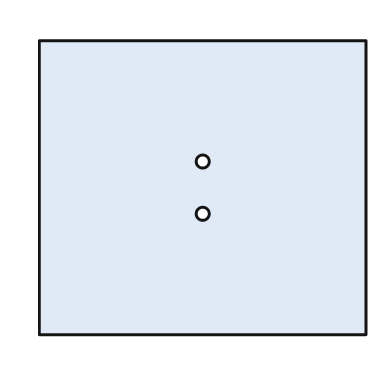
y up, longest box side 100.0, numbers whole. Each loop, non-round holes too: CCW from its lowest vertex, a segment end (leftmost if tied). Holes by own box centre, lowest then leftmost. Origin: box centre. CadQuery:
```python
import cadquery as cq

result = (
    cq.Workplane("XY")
    .moveTo(-50.0, -45.0)
    .lineTo(50.0, -45.0)
    .lineTo(50.0, 45.0)
    .lineTo(-50.0, 45.0)
    .close()
    .moveTo(0.0, -8.0)
    .circle(2.0)
    .moveTo(0.0, 8.0)
    .circle(2.0)
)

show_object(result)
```